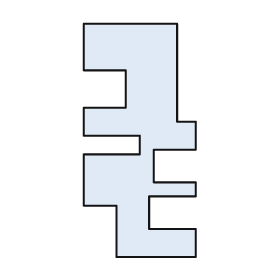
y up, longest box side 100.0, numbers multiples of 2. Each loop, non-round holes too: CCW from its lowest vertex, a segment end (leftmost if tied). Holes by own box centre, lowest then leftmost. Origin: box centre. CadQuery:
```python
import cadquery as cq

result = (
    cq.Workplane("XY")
    .moveTo(-10.0, -50.0)
    .lineTo(24.0, -50.0)
    .lineTo(24.0, -38.0)
    .lineTo(4.0, -38.0)
    .lineTo(4.0, -24.0)
    .lineTo(24.0, -24.0)
    .lineTo(24.0, -18.0)
    .lineTo(6.0, -18.0)
    .lineTo(6.0, -4.0)
    .lineTo(24.0, -4.0)
    .lineTo(24.0, 8.0)
    .lineTo(16.0, 8.0)
    .lineTo(16.0, 50.0)
    .lineTo(-24.0, 50.0)
    .lineTo(-24.0, 30.0)
    .lineTo(-6.0, 30.0)
    .lineTo(-6.0, 14.0)
    .lineTo(-24.0, 14.0)
    .lineTo(-24.0, 2.0)
    .lineTo(0.0, 2.0)
    .lineTo(0.0, -6.0)
    .lineTo(-24.0, -6.0)
    .lineTo(-24.0, -28.0)
    .lineTo(-10.0, -28.0)
    .close()
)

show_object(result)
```